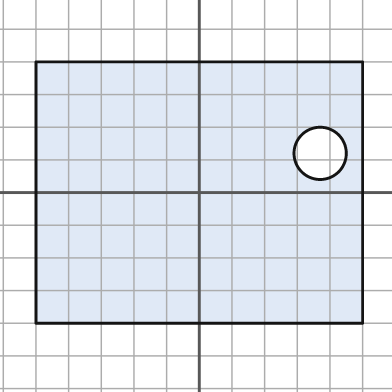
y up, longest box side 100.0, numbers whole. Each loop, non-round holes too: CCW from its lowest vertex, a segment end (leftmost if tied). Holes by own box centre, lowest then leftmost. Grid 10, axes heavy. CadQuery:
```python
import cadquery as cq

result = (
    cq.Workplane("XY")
    .moveTo(-50.0, -40.0)
    .lineTo(50.0, -40.0)
    .lineTo(50.0, 40.0)
    .lineTo(-50.0, 40.0)
    .close()
    .moveTo(37.0, 12.0)
    .circle(8.0)
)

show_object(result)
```